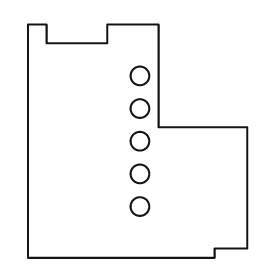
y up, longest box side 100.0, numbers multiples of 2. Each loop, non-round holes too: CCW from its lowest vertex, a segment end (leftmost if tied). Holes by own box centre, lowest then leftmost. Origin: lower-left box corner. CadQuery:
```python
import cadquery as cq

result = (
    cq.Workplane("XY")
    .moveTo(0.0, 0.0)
    .lineTo(80.0, 0.0)
    .lineTo(80.0, 4.0)
    .lineTo(94.0, 4.0)
    .lineTo(94.0, 56.0)
    .lineTo(56.0, 56.0)
    .lineTo(56.0, 100.0)
    .lineTo(34.0, 100.0)
    .lineTo(34.0, 92.0)
    .lineTo(8.0, 92.0)
    .lineTo(8.0, 100.0)
    .lineTo(0.0, 100.0)
    .close()
    .moveTo(48.0, 22.0)
    .circle(4.0)
    .moveTo(48.0, 36.0)
    .circle(4.0)
    .moveTo(48.0, 50.0)
    .circle(4.0)
    .moveTo(48.0, 64.0)
    .circle(4.0)
    .moveTo(48.0, 78.0)
    .circle(4.0)
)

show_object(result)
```